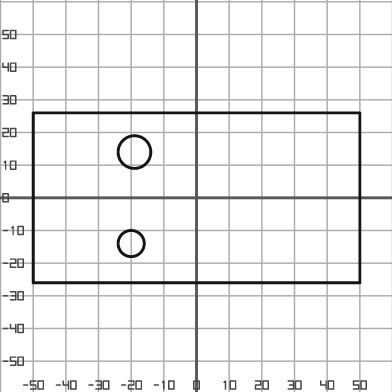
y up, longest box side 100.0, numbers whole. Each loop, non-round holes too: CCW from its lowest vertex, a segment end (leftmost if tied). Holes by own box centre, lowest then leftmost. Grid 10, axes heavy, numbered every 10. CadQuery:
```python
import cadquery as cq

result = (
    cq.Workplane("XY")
    .moveTo(-50.0, -26.0)
    .lineTo(50.0, -26.0)
    .lineTo(50.0, 26.0)
    .lineTo(-50.0, 26.0)
    .close()
    .moveTo(-20.0, -14.0)
    .circle(4.0)
    .moveTo(-19.0, 14.0)
    .circle(5.0)
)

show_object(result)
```